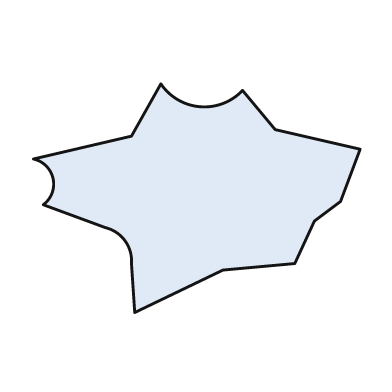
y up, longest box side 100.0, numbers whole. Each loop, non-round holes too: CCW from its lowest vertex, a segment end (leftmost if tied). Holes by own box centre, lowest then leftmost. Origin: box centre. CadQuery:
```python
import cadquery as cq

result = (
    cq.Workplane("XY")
    .moveTo(-19.0, -35.0)
    .lineTo(8.0, -22.0)
    .lineTo(30.0, -20.0)
    .lineTo(36.0, -7.0)
    .lineTo(44.0, -1.0)
    .lineTo(50.0, 15.0)
    .lineTo(24.0, 21.0)
    .lineTo(14.0, 33.0)
    .threePointArc((1.0, 28.0), (-11.0, 35.0))
    .lineTo(-20.0, 19.0)
    .lineTo(-50.0, 12.0)
    .threePointArc((-44.0, 6.0), (-47.0, -2.0))
    .lineTo(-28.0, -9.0)
    .threePointArc((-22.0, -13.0), (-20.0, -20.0))
    .close()
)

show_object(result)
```